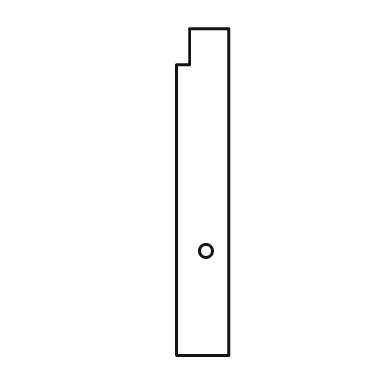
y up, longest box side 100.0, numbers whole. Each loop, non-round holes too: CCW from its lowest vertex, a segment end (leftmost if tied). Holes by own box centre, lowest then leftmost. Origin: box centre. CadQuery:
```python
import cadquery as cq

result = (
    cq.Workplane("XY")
    .moveTo(-8.0, -50.0)
    .lineTo(8.0, -50.0)
    .lineTo(8.0, 50.0)
    .lineTo(-4.0, 50.0)
    .lineTo(-4.0, 39.0)
    .lineTo(-8.0, 39.0)
    .close()
    .moveTo(1.0, -18.0)
    .circle(2.0)
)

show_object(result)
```